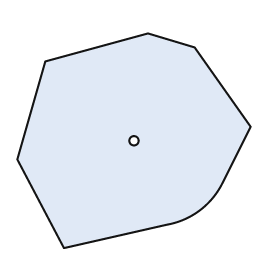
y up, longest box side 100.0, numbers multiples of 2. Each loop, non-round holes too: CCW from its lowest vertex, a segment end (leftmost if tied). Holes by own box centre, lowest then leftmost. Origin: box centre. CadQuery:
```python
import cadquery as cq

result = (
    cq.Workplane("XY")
    .moveTo(-30.0, -46.0)
    .lineTo(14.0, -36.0)
    .threePointArc((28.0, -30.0), (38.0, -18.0))
    .lineTo(50.0, 6.0)
    .lineTo(26.0, 40.0)
    .lineTo(6.0, 46.0)
    .lineTo(-38.0, 34.0)
    .lineTo(-50.0, -8.0)
    .close()
    .moveTo(0.0, 0.0)
    .circle(2.0)
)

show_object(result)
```